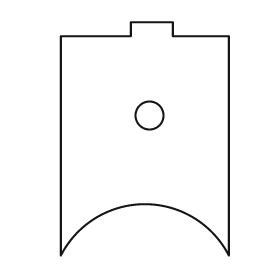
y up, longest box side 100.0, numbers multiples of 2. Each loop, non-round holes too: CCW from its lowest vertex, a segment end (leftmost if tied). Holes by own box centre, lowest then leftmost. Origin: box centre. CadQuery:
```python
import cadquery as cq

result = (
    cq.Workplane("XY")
    .moveTo(-36.0, -50.0)
    .threePointArc((0.0, -28.0), (36.0, -50.0))
    .lineTo(36.0, 44.0)
    .lineTo(12.0, 44.0)
    .lineTo(12.0, 50.0)
    .lineTo(-6.0, 50.0)
    .lineTo(-6.0, 44.0)
    .lineTo(-36.0, 44.0)
    .close()
    .moveTo(2.0, 10.0)
    .circle(6.0)
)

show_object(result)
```